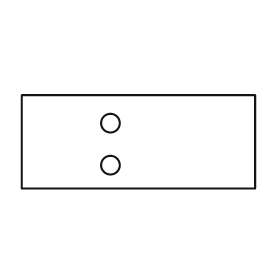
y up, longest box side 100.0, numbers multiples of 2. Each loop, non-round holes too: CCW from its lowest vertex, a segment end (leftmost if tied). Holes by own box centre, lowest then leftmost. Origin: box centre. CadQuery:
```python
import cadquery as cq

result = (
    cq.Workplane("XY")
    .moveTo(-50.0, -20.0)
    .lineTo(50.0, -20.0)
    .lineTo(50.0, 20.0)
    .lineTo(-50.0, 20.0)
    .close()
    .moveTo(-12.0, -10.0)
    .circle(4.0)
    .moveTo(-12.0, 8.0)
    .circle(4.0)
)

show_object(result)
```